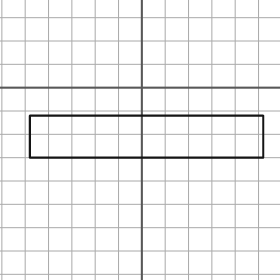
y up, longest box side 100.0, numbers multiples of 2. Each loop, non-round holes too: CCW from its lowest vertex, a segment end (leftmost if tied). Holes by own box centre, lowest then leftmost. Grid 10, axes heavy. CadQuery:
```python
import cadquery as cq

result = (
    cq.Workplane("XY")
    .moveTo(-48.0, -30.0)
    .lineTo(52.0, -30.0)
    .lineTo(52.0, -12.0)
    .lineTo(-48.0, -12.0)
    .close()
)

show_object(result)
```